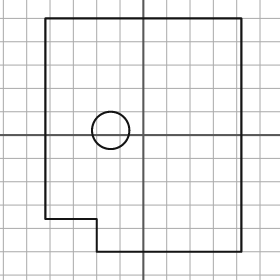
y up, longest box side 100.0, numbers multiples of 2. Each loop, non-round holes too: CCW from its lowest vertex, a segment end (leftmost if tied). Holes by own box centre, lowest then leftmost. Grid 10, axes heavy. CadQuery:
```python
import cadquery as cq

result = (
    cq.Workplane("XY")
    .moveTo(-20.0, -50.0)
    .lineTo(42.0, -50.0)
    .lineTo(42.0, 50.0)
    .lineTo(-42.0, 50.0)
    .lineTo(-42.0, -36.0)
    .lineTo(-20.0, -36.0)
    .close()
    .moveTo(-14.0, 2.0)
    .circle(8.0)
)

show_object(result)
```